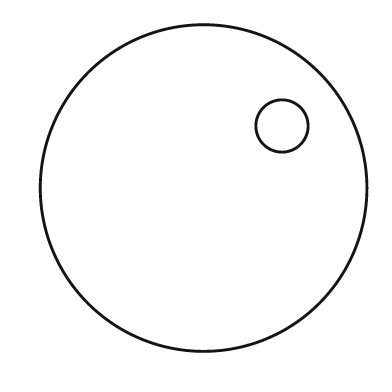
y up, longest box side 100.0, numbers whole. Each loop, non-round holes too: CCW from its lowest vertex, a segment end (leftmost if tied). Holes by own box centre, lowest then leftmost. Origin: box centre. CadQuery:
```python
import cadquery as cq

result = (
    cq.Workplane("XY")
    .moveTo(0.0, 0.0)
    .circle(50.0)
    .moveTo(24.0, 19.0)
    .circle(8.0)
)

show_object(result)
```